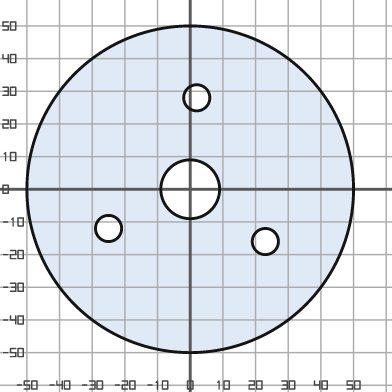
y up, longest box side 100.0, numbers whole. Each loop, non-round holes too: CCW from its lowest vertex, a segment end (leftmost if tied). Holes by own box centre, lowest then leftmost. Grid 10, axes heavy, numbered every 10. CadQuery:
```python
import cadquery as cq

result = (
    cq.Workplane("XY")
    .moveTo(0.0, 0.0)
    .circle(50.0)
    .moveTo(23.0, -16.0)
    .circle(4.0)
    .moveTo(-25.0, -12.0)
    .circle(4.0)
    .moveTo(0.0, 0.0)
    .circle(9.0)
    .moveTo(2.0, 28.0)
    .circle(4.0)
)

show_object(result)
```